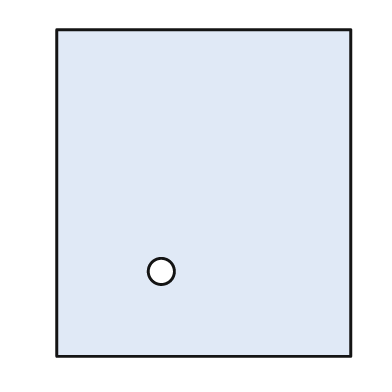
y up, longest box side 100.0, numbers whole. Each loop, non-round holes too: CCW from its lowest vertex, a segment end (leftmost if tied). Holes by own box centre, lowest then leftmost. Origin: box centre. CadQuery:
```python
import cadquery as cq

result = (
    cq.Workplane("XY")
    .moveTo(-45.0, -50.0)
    .lineTo(45.0, -50.0)
    .lineTo(45.0, 50.0)
    .lineTo(-45.0, 50.0)
    .close()
    .moveTo(-13.0, -24.0)
    .circle(4.0)
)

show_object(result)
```